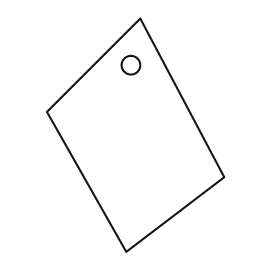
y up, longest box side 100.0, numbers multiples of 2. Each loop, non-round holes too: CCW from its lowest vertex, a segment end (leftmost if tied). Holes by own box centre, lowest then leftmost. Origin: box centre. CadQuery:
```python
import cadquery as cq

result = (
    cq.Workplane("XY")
    .moveTo(-4.0, -50.0)
    .lineTo(38.0, -18.0)
    .lineTo(2.0, 50.0)
    .lineTo(-38.0, 10.0)
    .close()
    .moveTo(-2.0, 30.0)
    .circle(4.0)
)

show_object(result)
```